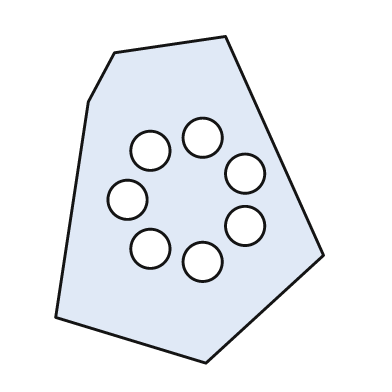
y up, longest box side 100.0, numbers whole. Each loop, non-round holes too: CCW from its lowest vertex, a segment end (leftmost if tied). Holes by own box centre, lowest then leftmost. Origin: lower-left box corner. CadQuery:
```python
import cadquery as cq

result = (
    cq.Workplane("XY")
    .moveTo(46.0, 0.0)
    .lineTo(82.0, 33.0)
    .lineTo(52.0, 100.0)
    .lineTo(18.0, 95.0)
    .lineTo(10.0, 80.0)
    .lineTo(0.0, 14.0)
    .close()
    .moveTo(45.0, 31.0)
    .circle(6.0)
    .moveTo(29.0, 35.0)
    .circle(6.0)
    .moveTo(58.0, 42.0)
    .circle(6.0)
    .moveTo(22.0, 50.0)
    .circle(6.0)
    .moveTo(58.0, 58.0)
    .circle(6.0)
    .moveTo(29.0, 65.0)
    .circle(6.0)
    .moveTo(45.0, 69.0)
    .circle(6.0)
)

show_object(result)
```